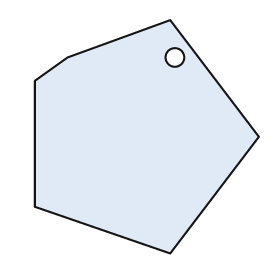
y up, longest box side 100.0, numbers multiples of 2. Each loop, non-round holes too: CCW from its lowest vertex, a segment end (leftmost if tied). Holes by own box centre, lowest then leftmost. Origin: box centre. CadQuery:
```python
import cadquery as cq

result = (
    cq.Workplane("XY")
    .moveTo(10.0, -50.0)
    .lineTo(48.0, 0.0)
    .lineTo(10.0, 50.0)
    .lineTo(-34.0, 34.0)
    .lineTo(-48.0, 24.0)
    .lineTo(-48.0, -30.0)
    .close()
    .moveTo(12.0, 34.0)
    .circle(4.0)
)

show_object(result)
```